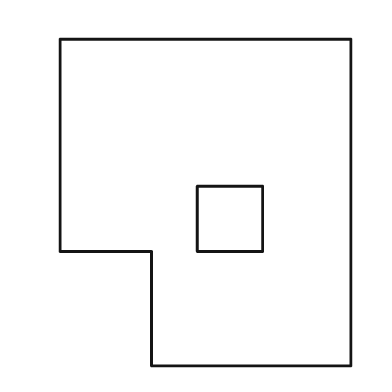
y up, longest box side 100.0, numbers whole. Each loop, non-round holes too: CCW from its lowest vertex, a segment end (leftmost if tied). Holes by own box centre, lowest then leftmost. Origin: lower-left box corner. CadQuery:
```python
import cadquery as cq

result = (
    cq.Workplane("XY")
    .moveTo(28.0, 0.0)
    .lineTo(89.0, 0.0)
    .lineTo(89.0, 100.0)
    .lineTo(0.0, 100.0)
    .lineTo(0.0, 35.0)
    .lineTo(28.0, 35.0)
    .close()
    .moveTo(42.0, 35.0)
    .lineTo(62.0, 35.0)
    .lineTo(62.0, 55.0)
    .lineTo(42.0, 55.0)
    .close()
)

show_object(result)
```